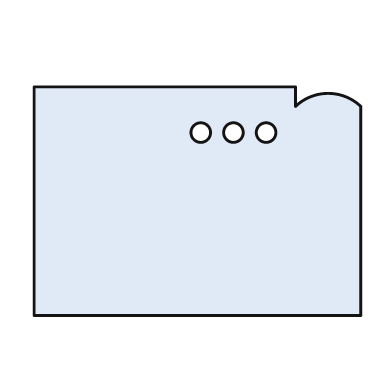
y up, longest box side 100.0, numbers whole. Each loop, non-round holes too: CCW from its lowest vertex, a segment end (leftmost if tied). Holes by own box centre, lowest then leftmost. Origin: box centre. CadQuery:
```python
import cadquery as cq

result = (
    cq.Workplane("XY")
    .moveTo(-50.0, -35.0)
    .lineTo(50.0, -35.0)
    .lineTo(50.0, 29.0)
    .threePointArc((40.0, 33.0), (30.0, 29.0))
    .lineTo(30.0, 35.0)
    .lineTo(-50.0, 35.0)
    .close()
    .moveTo(1.0, 21.0)
    .circle(3.0)
    .moveTo(11.0, 21.0)
    .circle(3.0)
    .moveTo(21.0, 21.0)
    .circle(3.0)
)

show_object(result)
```